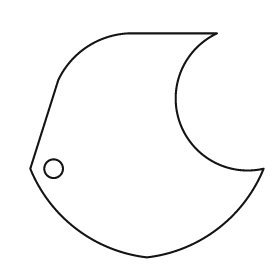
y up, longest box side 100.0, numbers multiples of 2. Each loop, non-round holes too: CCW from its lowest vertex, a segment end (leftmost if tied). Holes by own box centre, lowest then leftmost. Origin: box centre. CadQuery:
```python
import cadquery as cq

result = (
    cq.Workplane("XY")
    .moveTo(0.0, -48.0)
    .threePointArc((30.0, -36.0), (50.0, -10.0))
    .threePointArc((14.0, 10.0), (30.0, 48.0))
    .lineTo(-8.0, 48.0)
    .threePointArc((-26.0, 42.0), (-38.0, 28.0))
    .lineTo(-50.0, -10.0)
    .threePointArc((-30.0, -36.0), (0.0, -48.0))
    .close()
    .moveTo(-40.0, -10.0)
    .circle(4.0)
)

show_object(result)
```